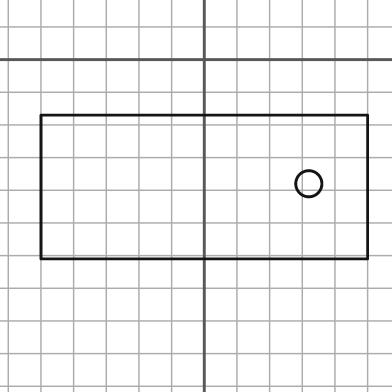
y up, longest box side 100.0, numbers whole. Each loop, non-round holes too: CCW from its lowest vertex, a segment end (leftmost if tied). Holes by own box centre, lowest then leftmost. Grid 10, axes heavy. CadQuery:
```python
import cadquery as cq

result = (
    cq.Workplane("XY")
    .moveTo(-50.0, -61.0)
    .lineTo(50.0, -61.0)
    .lineTo(50.0, -17.0)
    .lineTo(-50.0, -17.0)
    .close()
    .moveTo(32.0, -38.0)
    .circle(4.0)
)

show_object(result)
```